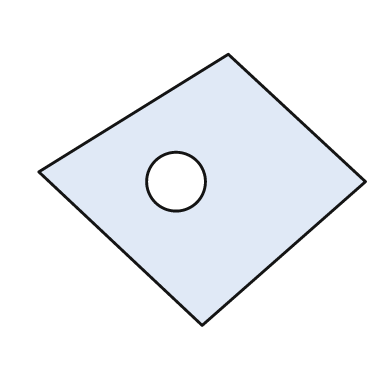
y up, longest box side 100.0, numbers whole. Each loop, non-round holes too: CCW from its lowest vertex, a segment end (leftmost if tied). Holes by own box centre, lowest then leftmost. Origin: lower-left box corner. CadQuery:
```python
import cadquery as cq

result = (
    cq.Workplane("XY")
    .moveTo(50.0, 0.0)
    .lineTo(100.0, 44.0)
    .lineTo(58.0, 83.0)
    .lineTo(0.0, 47.0)
    .close()
    .moveTo(42.0, 44.0)
    .circle(9.0)
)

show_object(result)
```